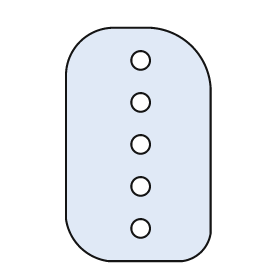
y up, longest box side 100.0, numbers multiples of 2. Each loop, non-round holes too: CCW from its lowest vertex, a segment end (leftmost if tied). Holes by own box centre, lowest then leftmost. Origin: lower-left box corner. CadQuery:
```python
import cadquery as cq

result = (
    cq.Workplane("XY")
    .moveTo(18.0, 0.0)
    .lineTo(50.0, 0.0)
    .threePointArc((58.0, 4.0), (62.0, 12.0))
    .lineTo(62.0, 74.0)
    .threePointArc((54.0, 92.0), (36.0, 100.0))
    .lineTo(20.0, 100.0)
    .threePointArc((6.0, 94.0), (0.0, 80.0))
    .lineTo(0.0, 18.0)
    .threePointArc((6.0, 6.0), (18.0, 0.0))
    .close()
    .moveTo(32.0, 14.0)
    .circle(4.0)
    .moveTo(32.0, 32.0)
    .circle(4.0)
    .moveTo(32.0, 50.0)
    .circle(4.0)
    .moveTo(32.0, 68.0)
    .circle(4.0)
    .moveTo(32.0, 86.0)
    .circle(4.0)
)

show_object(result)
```